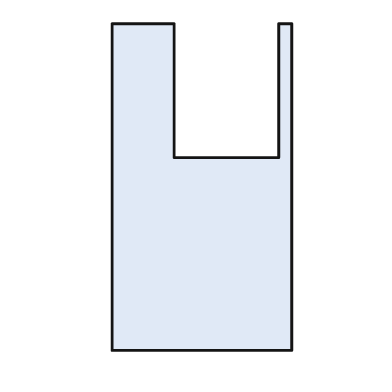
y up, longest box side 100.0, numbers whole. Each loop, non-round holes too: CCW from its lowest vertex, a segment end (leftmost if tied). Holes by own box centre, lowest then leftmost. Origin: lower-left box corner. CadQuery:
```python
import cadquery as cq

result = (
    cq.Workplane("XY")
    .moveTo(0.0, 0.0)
    .lineTo(55.0, 0.0)
    .lineTo(55.0, 100.0)
    .lineTo(51.0, 100.0)
    .lineTo(51.0, 59.0)
    .lineTo(19.0, 59.0)
    .lineTo(19.0, 100.0)
    .lineTo(0.0, 100.0)
    .close()
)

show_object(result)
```